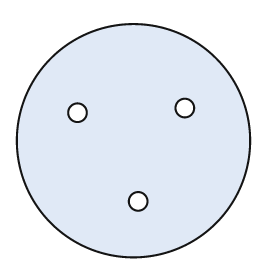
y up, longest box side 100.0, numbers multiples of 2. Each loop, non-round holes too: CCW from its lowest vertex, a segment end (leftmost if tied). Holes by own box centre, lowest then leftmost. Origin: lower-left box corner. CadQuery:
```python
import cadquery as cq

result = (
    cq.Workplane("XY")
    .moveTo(50.0, 50.0)
    .circle(50.0)
    .moveTo(52.0, 24.0)
    .circle(4.0)
    .moveTo(26.0, 62.0)
    .circle(4.0)
    .moveTo(72.0, 64.0)
    .circle(4.0)
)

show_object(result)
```